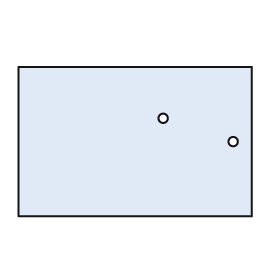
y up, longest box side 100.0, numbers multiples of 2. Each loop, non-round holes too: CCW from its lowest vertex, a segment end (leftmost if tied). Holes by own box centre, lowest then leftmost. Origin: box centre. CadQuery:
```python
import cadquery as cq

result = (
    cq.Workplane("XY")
    .moveTo(-50.0, -32.0)
    .lineTo(50.0, -32.0)
    .lineTo(50.0, 32.0)
    .lineTo(-50.0, 32.0)
    .close()
    .moveTo(42.0, 0.0)
    .circle(2.0)
    .moveTo(12.0, 10.0)
    .circle(2.0)
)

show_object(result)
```